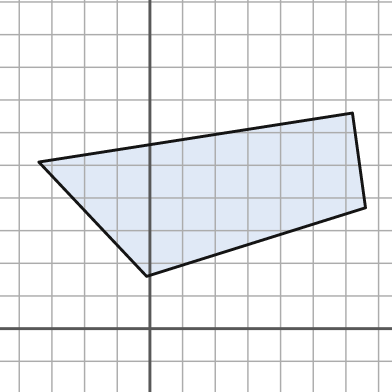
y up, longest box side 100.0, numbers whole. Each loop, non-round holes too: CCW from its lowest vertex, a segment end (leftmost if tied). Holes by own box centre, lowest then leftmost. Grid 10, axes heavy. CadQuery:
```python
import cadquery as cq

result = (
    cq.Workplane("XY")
    .moveTo(-1.0, 16.0)
    .lineTo(66.0, 37.0)
    .lineTo(62.0, 66.0)
    .lineTo(-34.0, 51.0)
    .close()
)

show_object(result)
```